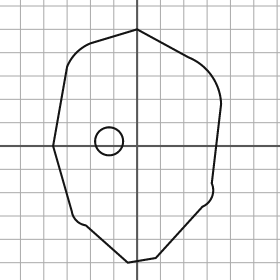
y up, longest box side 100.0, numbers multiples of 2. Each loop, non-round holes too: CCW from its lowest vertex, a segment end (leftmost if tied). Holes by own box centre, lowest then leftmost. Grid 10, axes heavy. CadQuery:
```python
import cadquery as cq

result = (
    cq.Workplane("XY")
    .moveTo(-4.0, -50.0)
    .lineTo(8.0, -48.0)
    .lineTo(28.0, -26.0)
    .threePointArc((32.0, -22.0), (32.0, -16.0))
    .lineTo(36.0, 18.0)
    .threePointArc((32.0, 30.0), (22.0, 38.0))
    .lineTo(0.0, 50.0)
    .lineTo(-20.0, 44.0)
    .threePointArc((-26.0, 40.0), (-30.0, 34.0))
    .lineTo(-36.0, 0.0)
    .lineTo(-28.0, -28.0)
    .threePointArc((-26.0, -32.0), (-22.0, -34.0))
    .close()
    .moveTo(-12.0, 2.0)
    .circle(6.0)
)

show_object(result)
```